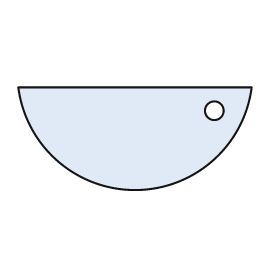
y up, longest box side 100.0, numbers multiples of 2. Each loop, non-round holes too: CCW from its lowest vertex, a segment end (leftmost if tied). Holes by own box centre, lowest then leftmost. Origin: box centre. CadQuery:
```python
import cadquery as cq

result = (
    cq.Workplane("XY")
    .moveTo(-50.0, 22.0)
    .threePointArc((0.0, -22.0), (50.0, 22.0))
    .close()
    .moveTo(34.0, 12.0)
    .circle(4.0)
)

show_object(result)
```